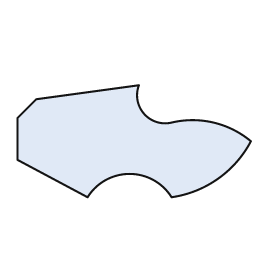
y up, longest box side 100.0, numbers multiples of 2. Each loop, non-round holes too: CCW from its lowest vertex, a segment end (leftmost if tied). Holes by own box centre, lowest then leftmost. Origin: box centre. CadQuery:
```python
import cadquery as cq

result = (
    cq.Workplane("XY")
    .moveTo(-20.0, -24.0)
    .threePointArc((-2.0, -14.0), (16.0, -24.0))
    .threePointArc((36.0, -16.0), (50.0, 0.0))
    .threePointArc((34.0, 8.0), (16.0, 8.0))
    .threePointArc((4.0, 12.0), (2.0, 24.0))
    .lineTo(-42.0, 18.0)
    .lineTo(-50.0, 10.0)
    .lineTo(-50.0, -8.0)
    .close()
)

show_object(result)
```